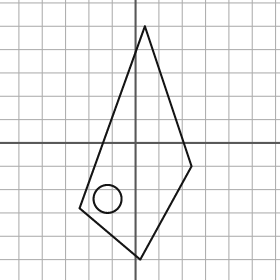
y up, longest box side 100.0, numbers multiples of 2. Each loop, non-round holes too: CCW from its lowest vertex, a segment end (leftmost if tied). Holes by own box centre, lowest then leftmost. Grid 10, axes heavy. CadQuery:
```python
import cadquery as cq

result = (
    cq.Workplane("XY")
    .moveTo(2.0, -50.0)
    .lineTo(24.0, -10.0)
    .lineTo(4.0, 50.0)
    .lineTo(-24.0, -28.0)
    .close()
    .moveTo(-12.0, -24.0)
    .circle(6.0)
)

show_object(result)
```